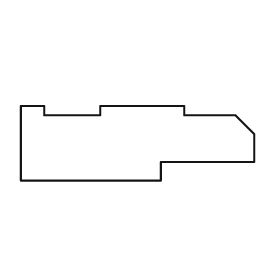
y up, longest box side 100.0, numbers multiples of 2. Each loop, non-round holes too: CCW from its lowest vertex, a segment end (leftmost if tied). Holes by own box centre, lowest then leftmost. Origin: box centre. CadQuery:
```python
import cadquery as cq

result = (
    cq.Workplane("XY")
    .moveTo(-50.0, -16.0)
    .lineTo(10.0, -16.0)
    .lineTo(10.0, -8.0)
    .lineTo(50.0, -8.0)
    .lineTo(50.0, 4.0)
    .lineTo(42.0, 12.0)
    .lineTo(20.0, 12.0)
    .lineTo(20.0, 16.0)
    .lineTo(-16.0, 16.0)
    .lineTo(-16.0, 12.0)
    .lineTo(-40.0, 12.0)
    .lineTo(-40.0, 16.0)
    .lineTo(-50.0, 16.0)
    .close()
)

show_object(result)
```